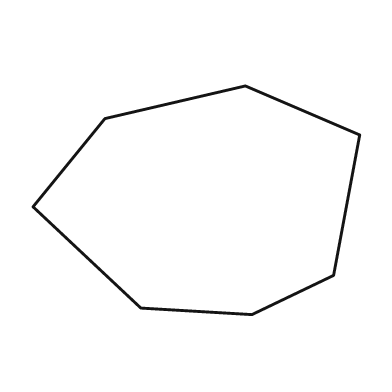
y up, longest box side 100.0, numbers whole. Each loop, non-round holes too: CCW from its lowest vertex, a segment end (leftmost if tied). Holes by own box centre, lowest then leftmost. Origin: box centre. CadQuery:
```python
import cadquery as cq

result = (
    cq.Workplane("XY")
    .moveTo(17.0, -35.0)
    .lineTo(42.0, -23.0)
    .lineTo(50.0, 20.0)
    .lineTo(15.0, 35.0)
    .lineTo(-28.0, 25.0)
    .lineTo(-50.0, -2.0)
    .lineTo(-17.0, -33.0)
    .close()
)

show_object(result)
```